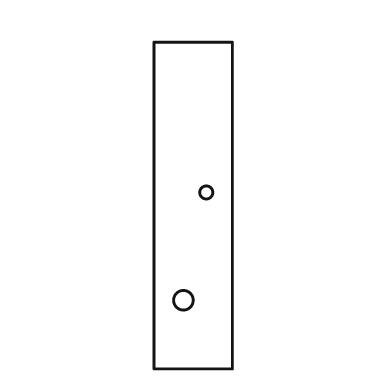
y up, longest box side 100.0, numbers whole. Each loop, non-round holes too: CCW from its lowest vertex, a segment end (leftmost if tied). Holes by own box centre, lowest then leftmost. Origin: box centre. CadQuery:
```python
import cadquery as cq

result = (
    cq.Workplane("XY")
    .moveTo(-12.0, -50.0)
    .lineTo(12.0, -50.0)
    .lineTo(12.0, 50.0)
    .lineTo(-12.0, 50.0)
    .close()
    .moveTo(-3.0, -29.0)
    .circle(3.0)
    .moveTo(4.0, 4.0)
    .circle(2.0)
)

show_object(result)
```